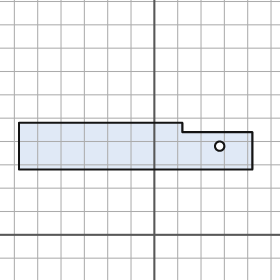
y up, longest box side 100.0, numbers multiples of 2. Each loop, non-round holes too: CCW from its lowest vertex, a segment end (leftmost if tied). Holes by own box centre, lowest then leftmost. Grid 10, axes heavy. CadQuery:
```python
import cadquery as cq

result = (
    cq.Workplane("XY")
    .moveTo(-58.0, 28.0)
    .lineTo(42.0, 28.0)
    .lineTo(42.0, 44.0)
    .lineTo(12.0, 44.0)
    .lineTo(12.0, 48.0)
    .lineTo(-58.0, 48.0)
    .close()
    .moveTo(28.0, 38.0)
    .circle(2.0)
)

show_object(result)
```